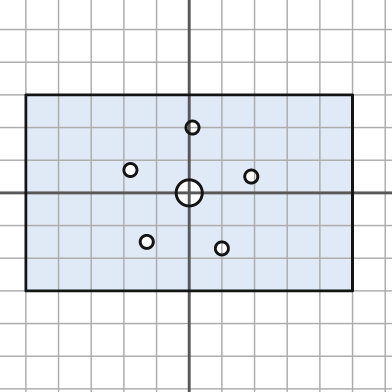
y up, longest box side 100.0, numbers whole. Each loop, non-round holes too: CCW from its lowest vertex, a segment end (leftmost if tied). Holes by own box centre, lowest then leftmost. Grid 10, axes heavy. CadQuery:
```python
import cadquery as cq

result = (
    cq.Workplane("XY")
    .moveTo(-50.0, -30.0)
    .lineTo(50.0, -30.0)
    .lineTo(50.0, 30.0)
    .lineTo(-50.0, 30.0)
    .close()
    .moveTo(10.0, -17.0)
    .circle(2.0)
    .moveTo(-13.0, -15.0)
    .circle(2.0)
    .moveTo(0.0, 0.0)
    .circle(4.0)
    .moveTo(19.0, 5.0)
    .circle(2.0)
    .moveTo(-18.0, 7.0)
    .circle(2.0)
    .moveTo(1.0, 20.0)
    .circle(2.0)
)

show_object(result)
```